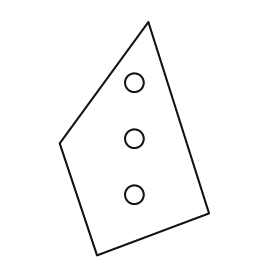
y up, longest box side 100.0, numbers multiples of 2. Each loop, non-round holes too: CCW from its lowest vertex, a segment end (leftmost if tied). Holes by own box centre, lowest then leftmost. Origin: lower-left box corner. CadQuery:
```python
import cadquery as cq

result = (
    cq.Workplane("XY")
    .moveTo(16.0, 0.0)
    .lineTo(64.0, 18.0)
    .lineTo(38.0, 100.0)
    .lineTo(0.0, 48.0)
    .close()
    .moveTo(32.0, 26.0)
    .circle(4.0)
    .moveTo(32.0, 50.0)
    .circle(4.0)
    .moveTo(32.0, 74.0)
    .circle(4.0)
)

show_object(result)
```